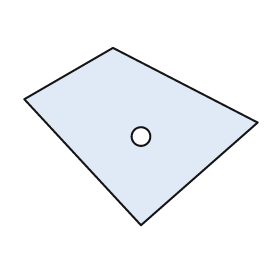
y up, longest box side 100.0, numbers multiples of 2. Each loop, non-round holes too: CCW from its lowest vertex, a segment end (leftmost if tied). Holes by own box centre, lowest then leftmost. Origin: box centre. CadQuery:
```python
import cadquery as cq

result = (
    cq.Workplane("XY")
    .moveTo(0.0, -38.0)
    .lineTo(50.0, 6.0)
    .lineTo(-12.0, 38.0)
    .lineTo(-50.0, 16.0)
    .close()
    .moveTo(0.0, 0.0)
    .circle(4.0)
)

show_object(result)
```